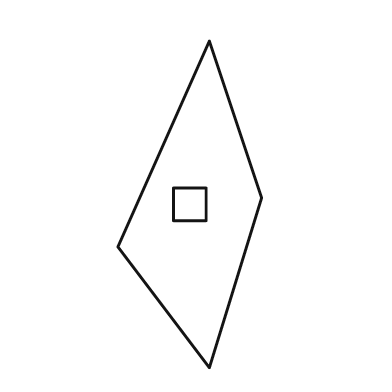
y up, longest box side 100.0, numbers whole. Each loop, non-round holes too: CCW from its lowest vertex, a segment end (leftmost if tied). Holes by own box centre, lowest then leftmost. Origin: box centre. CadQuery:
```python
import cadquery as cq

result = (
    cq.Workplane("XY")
    .moveTo(6.0, -50.0)
    .lineTo(22.0, 2.0)
    .lineTo(6.0, 50.0)
    .lineTo(-22.0, -13.0)
    .close()
    .moveTo(-5.0, -5.0)
    .lineTo(5.0, -5.0)
    .lineTo(5.0, 5.0)
    .lineTo(-5.0, 5.0)
    .close()
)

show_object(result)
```